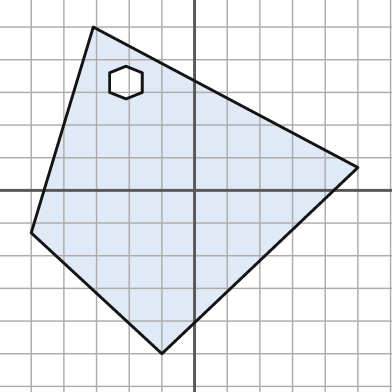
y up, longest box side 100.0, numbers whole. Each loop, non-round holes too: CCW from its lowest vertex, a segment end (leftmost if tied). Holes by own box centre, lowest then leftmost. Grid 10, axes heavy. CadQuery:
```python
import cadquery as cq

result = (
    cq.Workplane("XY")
    .moveTo(-10.0, -50.0)
    .lineTo(50.0, 7.0)
    .lineTo(-31.0, 50.0)
    .lineTo(-50.0, -13.0)
    .close()
    .moveTo(-21.0, 28.0)
    .lineTo(-16.0, 30.0)
    .lineTo(-16.0, 36.0)
    .lineTo(-21.0, 38.0)
    .lineTo(-26.0, 36.0)
    .lineTo(-26.0, 30.0)
    .close()
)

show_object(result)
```